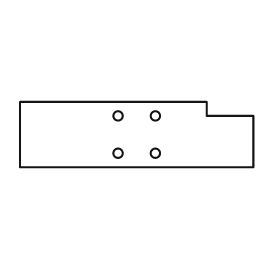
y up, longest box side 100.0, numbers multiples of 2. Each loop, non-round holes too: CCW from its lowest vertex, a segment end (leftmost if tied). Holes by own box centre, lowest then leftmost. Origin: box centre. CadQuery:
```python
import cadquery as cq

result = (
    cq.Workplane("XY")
    .moveTo(-50.0, -14.0)
    .lineTo(50.0, -14.0)
    .lineTo(50.0, 8.0)
    .lineTo(30.0, 8.0)
    .lineTo(30.0, 14.0)
    .lineTo(-50.0, 14.0)
    .close()
    .moveTo(-8.0, -8.0)
    .circle(2.0)
    .moveTo(8.0, -8.0)
    .circle(2.0)
    .moveTo(-8.0, 8.0)
    .circle(2.0)
    .moveTo(8.0, 8.0)
    .circle(2.0)
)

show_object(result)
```